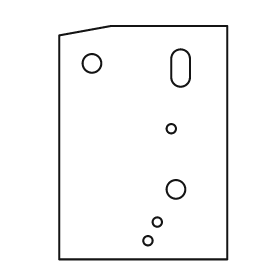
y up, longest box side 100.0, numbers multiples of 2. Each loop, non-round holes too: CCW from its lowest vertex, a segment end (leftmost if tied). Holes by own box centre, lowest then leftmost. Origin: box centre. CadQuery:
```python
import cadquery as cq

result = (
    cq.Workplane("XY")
    .moveTo(-36.0, -50.0)
    .lineTo(36.0, -50.0)
    .lineTo(36.0, 50.0)
    .lineTo(-14.0, 50.0)
    .lineTo(-36.0, 46.0)
    .close()
    .moveTo(2.0, -42.0)
    .circle(2.0)
    .moveTo(6.0, -34.0)
    .circle(2.0)
    .moveTo(14.0, -20.0)
    .circle(4.0)
    .moveTo(12.0, 6.0)
    .circle(2.0)
    .moveTo(12.0, 28.0)
    .threePointArc((16.0, 24.0), (20.0, 28.0))
    .lineTo(20.0, 36.0)
    .threePointArc((16.0, 40.0), (12.0, 36.0))
    .close()
    .moveTo(-22.0, 34.0)
    .circle(4.0)
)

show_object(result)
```